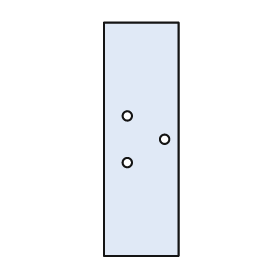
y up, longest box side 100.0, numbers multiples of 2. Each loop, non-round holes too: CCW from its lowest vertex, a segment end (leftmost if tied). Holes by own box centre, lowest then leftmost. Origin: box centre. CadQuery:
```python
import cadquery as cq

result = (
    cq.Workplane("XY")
    .moveTo(-16.0, -50.0)
    .lineTo(16.0, -50.0)
    .lineTo(16.0, 50.0)
    .lineTo(-16.0, 50.0)
    .close()
    .moveTo(-6.0, -10.0)
    .circle(2.0)
    .moveTo(10.0, 0.0)
    .circle(2.0)
    .moveTo(-6.0, 10.0)
    .circle(2.0)
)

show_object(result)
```